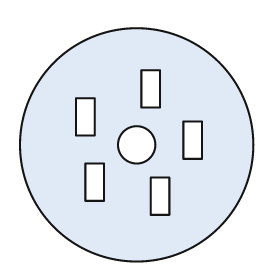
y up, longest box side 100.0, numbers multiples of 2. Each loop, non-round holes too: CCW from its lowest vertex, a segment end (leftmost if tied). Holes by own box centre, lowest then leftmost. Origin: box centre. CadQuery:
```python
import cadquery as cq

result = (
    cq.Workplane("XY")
    .moveTo(0.0, 0.0)
    .circle(50.0)
    .moveTo(6.0, -30.0)
    .lineTo(14.0, -30.0)
    .lineTo(14.0, -14.0)
    .lineTo(6.0, -14.0)
    .close()
    .moveTo(-22.0, -24.0)
    .lineTo(-14.0, -24.0)
    .lineTo(-14.0, -8.0)
    .lineTo(-22.0, -8.0)
    .close()
    .moveTo(0.0, 0.0)
    .circle(8.0)
    .moveTo(20.0, -6.0)
    .lineTo(28.0, -6.0)
    .lineTo(28.0, 10.0)
    .lineTo(20.0, 10.0)
    .close()
    .moveTo(-26.0, 4.0)
    .lineTo(-18.0, 4.0)
    .lineTo(-18.0, 20.0)
    .lineTo(-26.0, 20.0)
    .close()
    .moveTo(2.0, 16.0)
    .lineTo(10.0, 16.0)
    .lineTo(10.0, 32.0)
    .lineTo(2.0, 32.0)
    .close()
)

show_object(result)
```